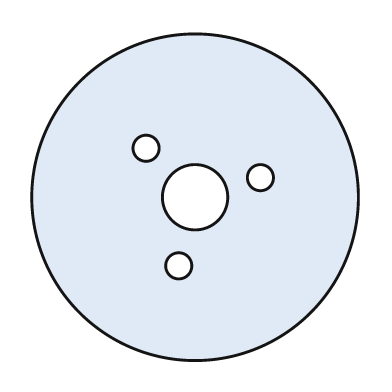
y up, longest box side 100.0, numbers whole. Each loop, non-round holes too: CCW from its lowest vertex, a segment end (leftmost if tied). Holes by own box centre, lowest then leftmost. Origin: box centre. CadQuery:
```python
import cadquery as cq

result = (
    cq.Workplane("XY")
    .moveTo(0.0, 0.0)
    .circle(50.0)
    .moveTo(-5.0, -21.0)
    .circle(4.0)
    .moveTo(0.0, 0.0)
    .circle(10.0)
    .moveTo(20.0, 6.0)
    .circle(4.0)
    .moveTo(-15.0, 15.0)
    .circle(4.0)
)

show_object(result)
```